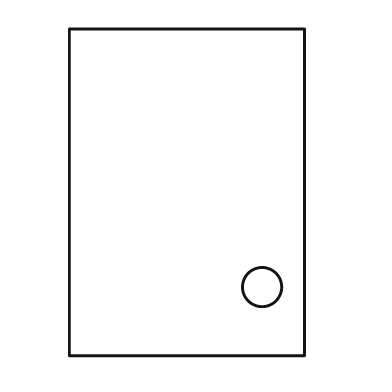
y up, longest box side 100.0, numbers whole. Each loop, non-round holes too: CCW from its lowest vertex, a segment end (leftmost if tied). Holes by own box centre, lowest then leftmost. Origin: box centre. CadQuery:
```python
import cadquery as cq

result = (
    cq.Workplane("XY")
    .moveTo(-36.0, -50.0)
    .lineTo(36.0, -50.0)
    .lineTo(36.0, 50.0)
    .lineTo(-36.0, 50.0)
    .close()
    .moveTo(23.0, -29.0)
    .circle(6.0)
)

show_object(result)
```